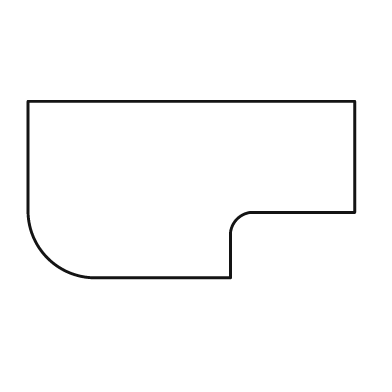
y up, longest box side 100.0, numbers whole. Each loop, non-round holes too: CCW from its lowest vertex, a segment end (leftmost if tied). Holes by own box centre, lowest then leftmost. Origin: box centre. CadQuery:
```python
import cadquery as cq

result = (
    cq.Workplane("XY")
    .moveTo(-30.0, -27.0)
    .lineTo(12.0, -27.0)
    .lineTo(12.0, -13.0)
    .threePointArc((14.0, -9.0), (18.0, -7.0))
    .lineTo(50.0, -7.0)
    .lineTo(50.0, 27.0)
    .lineTo(-50.0, 27.0)
    .lineTo(-50.0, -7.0)
    .threePointArc((-44.0, -21.0), (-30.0, -27.0))
    .close()
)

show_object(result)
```